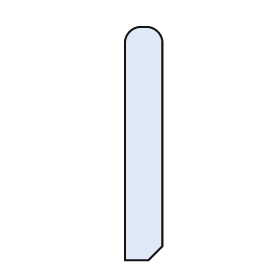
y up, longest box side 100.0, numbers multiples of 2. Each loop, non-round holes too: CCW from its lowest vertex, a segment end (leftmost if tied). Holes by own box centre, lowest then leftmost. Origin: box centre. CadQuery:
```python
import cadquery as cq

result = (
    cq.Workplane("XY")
    .moveTo(-8.0, -50.0)
    .lineTo(2.0, -50.0)
    .lineTo(8.0, -44.0)
    .lineTo(8.0, 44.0)
    .threePointArc((6.0, 48.0), (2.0, 50.0))
    .lineTo(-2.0, 50.0)
    .threePointArc((-6.0, 48.0), (-8.0, 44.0))
    .close()
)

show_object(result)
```